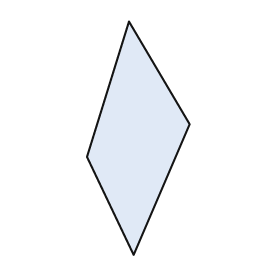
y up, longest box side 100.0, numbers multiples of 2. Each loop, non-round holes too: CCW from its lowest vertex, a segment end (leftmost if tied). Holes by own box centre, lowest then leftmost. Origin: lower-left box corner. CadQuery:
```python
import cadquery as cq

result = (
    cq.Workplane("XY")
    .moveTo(20.0, 0.0)
    .lineTo(44.0, 56.0)
    .lineTo(18.0, 100.0)
    .lineTo(0.0, 42.0)
    .close()
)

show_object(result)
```